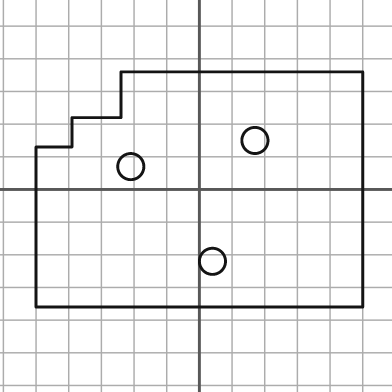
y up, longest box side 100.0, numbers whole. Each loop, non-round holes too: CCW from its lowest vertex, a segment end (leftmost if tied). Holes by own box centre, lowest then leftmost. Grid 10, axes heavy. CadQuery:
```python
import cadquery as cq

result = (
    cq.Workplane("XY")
    .moveTo(-50.0, -36.0)
    .lineTo(50.0, -36.0)
    .lineTo(50.0, 36.0)
    .lineTo(-24.0, 36.0)
    .lineTo(-24.0, 22.0)
    .lineTo(-39.0, 22.0)
    .lineTo(-39.0, 13.0)
    .lineTo(-50.0, 13.0)
    .close()
    .moveTo(4.0, -22.0)
    .circle(4.0)
    .moveTo(-21.0, 7.0)
    .circle(4.0)
    .moveTo(17.0, 15.0)
    .circle(4.0)
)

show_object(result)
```